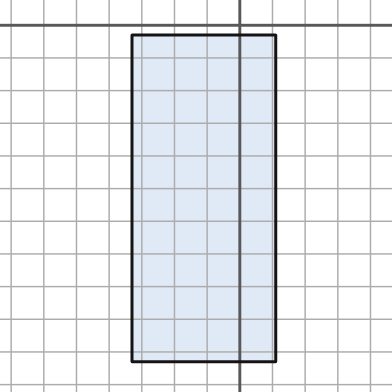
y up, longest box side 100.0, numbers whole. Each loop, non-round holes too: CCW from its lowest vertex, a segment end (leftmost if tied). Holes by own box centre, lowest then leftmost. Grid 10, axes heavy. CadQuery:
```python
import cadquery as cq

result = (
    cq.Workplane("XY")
    .moveTo(-33.0, -103.0)
    .lineTo(11.0, -103.0)
    .lineTo(11.0, -3.0)
    .lineTo(-33.0, -3.0)
    .close()
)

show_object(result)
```